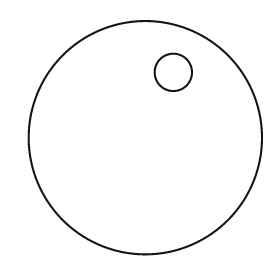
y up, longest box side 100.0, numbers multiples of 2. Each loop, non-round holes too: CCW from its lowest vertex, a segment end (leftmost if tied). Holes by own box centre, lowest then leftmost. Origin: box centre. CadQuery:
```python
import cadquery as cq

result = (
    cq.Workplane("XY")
    .moveTo(0.0, 0.0)
    .circle(50.0)
    .moveTo(12.0, 28.0)
    .circle(8.0)
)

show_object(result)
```